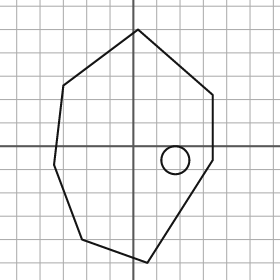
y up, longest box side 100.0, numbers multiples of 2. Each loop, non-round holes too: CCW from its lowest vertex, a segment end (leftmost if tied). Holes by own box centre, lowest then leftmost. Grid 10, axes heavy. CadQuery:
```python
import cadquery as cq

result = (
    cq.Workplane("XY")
    .moveTo(6.0, -50.0)
    .lineTo(34.0, -6.0)
    .lineTo(34.0, 22.0)
    .lineTo(2.0, 50.0)
    .lineTo(-30.0, 26.0)
    .lineTo(-34.0, -8.0)
    .lineTo(-22.0, -40.0)
    .close()
    .moveTo(18.0, -6.0)
    .circle(6.0)
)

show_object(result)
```